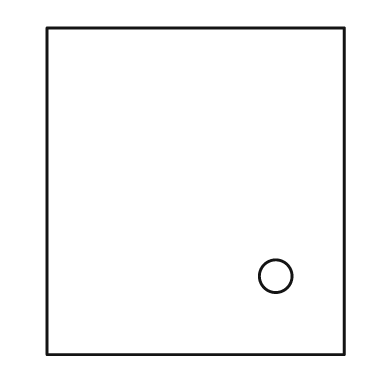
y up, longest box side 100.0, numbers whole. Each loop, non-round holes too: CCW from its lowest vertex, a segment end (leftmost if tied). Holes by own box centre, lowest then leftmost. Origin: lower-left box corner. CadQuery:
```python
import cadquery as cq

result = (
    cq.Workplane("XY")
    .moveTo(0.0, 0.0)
    .lineTo(91.0, 0.0)
    .lineTo(91.0, 100.0)
    .lineTo(0.0, 100.0)
    .close()
    .moveTo(70.0, 24.0)
    .circle(5.0)
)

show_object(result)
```